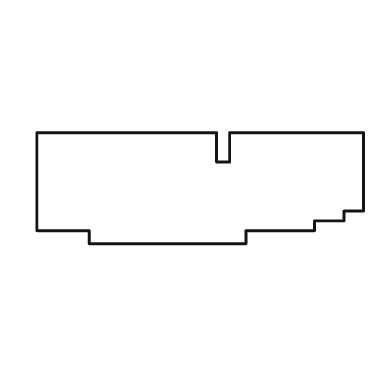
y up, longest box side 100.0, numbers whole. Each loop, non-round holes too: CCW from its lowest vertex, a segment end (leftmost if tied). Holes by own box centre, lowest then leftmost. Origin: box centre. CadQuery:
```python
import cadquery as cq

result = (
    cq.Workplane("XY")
    .moveTo(-34.0, -17.0)
    .lineTo(14.0, -17.0)
    .lineTo(14.0, -13.0)
    .lineTo(35.0, -13.0)
    .lineTo(35.0, -10.0)
    .lineTo(44.0, -10.0)
    .lineTo(44.0, -7.0)
    .lineTo(50.0, -7.0)
    .lineTo(50.0, 17.0)
    .lineTo(9.0, 17.0)
    .lineTo(9.0, 8.0)
    .lineTo(5.0, 8.0)
    .lineTo(5.0, 17.0)
    .lineTo(-50.0, 17.0)
    .lineTo(-50.0, -13.0)
    .lineTo(-34.0, -13.0)
    .close()
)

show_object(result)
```